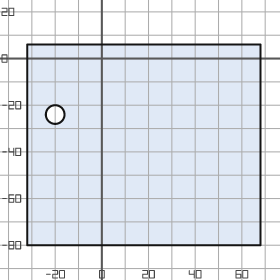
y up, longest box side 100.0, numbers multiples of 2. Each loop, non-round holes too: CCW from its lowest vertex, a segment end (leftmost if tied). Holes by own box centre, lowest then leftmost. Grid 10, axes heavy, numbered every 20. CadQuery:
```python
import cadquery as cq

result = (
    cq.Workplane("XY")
    .moveTo(-32.0, -80.0)
    .lineTo(68.0, -80.0)
    .lineTo(68.0, 6.0)
    .lineTo(-32.0, 6.0)
    .close()
    .moveTo(-20.0, -24.0)
    .circle(4.0)
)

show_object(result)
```